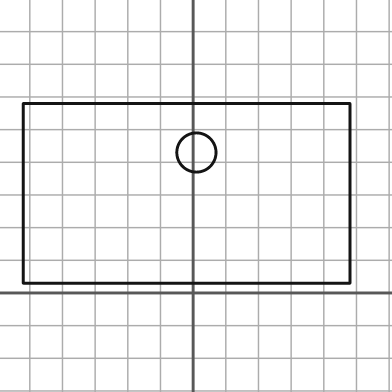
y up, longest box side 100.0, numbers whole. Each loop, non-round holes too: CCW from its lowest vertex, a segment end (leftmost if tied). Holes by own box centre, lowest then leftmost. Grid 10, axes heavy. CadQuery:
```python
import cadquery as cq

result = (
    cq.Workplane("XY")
    .moveTo(-52.0, 3.0)
    .lineTo(48.0, 3.0)
    .lineTo(48.0, 58.0)
    .lineTo(-52.0, 58.0)
    .close()
    .moveTo(1.0, 43.0)
    .circle(6.0)
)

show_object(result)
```